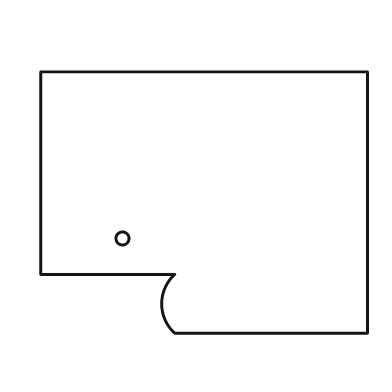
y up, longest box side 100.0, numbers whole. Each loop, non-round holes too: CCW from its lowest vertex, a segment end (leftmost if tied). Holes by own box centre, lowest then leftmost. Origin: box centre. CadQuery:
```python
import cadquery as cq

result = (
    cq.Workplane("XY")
    .moveTo(-9.0, -40.0)
    .lineTo(50.0, -40.0)
    .lineTo(50.0, 40.0)
    .lineTo(-50.0, 40.0)
    .lineTo(-50.0, -22.0)
    .lineTo(-9.0, -22.0)
    .threePointArc((-13.0, -31.0), (-9.0, -40.0))
    .close()
    .moveTo(-25.0, -11.0)
    .circle(2.0)
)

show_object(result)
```